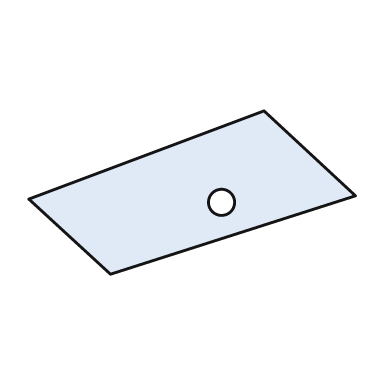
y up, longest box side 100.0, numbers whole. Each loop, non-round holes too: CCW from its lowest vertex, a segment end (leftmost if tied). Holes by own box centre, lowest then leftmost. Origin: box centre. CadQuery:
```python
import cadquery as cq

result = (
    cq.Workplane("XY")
    .moveTo(-25.0, -25.0)
    .lineTo(50.0, -1.0)
    .lineTo(22.0, 25.0)
    .lineTo(-50.0, -2.0)
    .close()
    .moveTo(9.0, -3.0)
    .circle(4.0)
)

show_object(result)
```